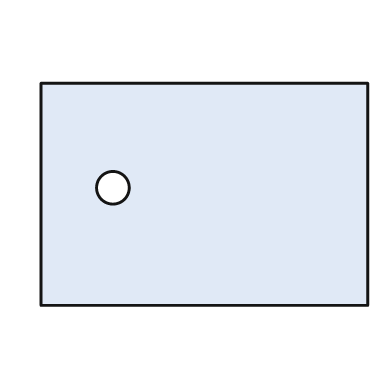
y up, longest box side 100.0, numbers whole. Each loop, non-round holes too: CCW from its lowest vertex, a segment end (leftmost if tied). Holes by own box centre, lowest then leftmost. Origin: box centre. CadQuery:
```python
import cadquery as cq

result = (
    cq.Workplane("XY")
    .moveTo(-50.0, -34.0)
    .lineTo(50.0, -34.0)
    .lineTo(50.0, 34.0)
    .lineTo(-50.0, 34.0)
    .close()
    .moveTo(-28.0, 2.0)
    .circle(5.0)
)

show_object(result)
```